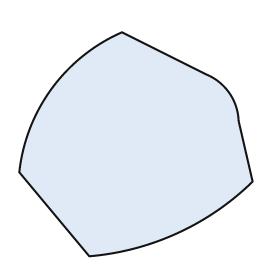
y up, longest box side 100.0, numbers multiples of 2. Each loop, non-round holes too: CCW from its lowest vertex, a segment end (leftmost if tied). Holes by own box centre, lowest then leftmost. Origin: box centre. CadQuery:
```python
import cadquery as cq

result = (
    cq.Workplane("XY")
    .moveTo(-20.0, -48.0)
    .threePointArc((18.0, -38.0), (50.0, -16.0))
    .lineTo(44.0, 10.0)
    .threePointArc((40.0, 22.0), (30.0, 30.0))
    .lineTo(-6.0, 48.0)
    .threePointArc((-36.0, 24.0), (-50.0, -12.0))
    .close()
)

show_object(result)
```